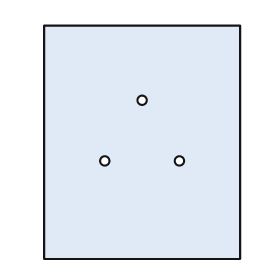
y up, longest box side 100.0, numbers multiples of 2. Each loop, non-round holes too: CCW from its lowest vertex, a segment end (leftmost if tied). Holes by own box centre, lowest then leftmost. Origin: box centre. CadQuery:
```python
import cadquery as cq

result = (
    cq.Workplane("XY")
    .moveTo(-42.0, -50.0)
    .lineTo(42.0, -50.0)
    .lineTo(42.0, 50.0)
    .lineTo(-42.0, 50.0)
    .close()
    .moveTo(-16.0, -8.0)
    .circle(2.0)
    .moveTo(16.0, -8.0)
    .circle(2.0)
    .moveTo(0.0, 18.0)
    .circle(2.0)
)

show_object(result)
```